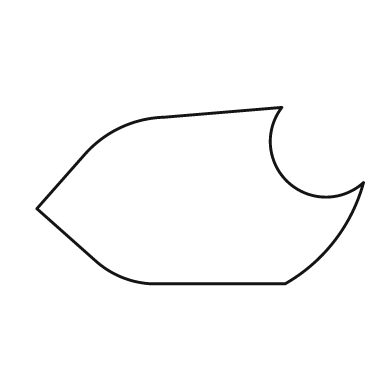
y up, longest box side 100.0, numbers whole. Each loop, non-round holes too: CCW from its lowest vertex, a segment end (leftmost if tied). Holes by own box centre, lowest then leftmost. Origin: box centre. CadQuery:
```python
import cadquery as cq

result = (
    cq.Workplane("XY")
    .moveTo(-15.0, -27.0)
    .lineTo(26.0, -27.0)
    .threePointArc((41.0, -14.0), (50.0, 4.0))
    .threePointArc((27.0, 4.0), (25.0, 27.0))
    .lineTo(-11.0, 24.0)
    .threePointArc((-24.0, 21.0), (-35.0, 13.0))
    .lineTo(-50.0, -4.0)
    .lineTo(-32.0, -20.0)
    .threePointArc((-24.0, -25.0), (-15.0, -27.0))
    .close()
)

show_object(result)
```